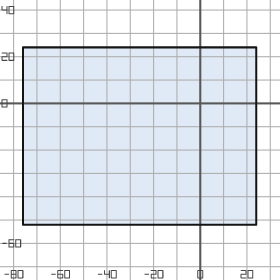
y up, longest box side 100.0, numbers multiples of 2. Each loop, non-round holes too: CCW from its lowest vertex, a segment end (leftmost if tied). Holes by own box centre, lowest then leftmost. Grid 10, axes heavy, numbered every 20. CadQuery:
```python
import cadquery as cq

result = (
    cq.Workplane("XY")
    .moveTo(-76.0, -52.0)
    .lineTo(24.0, -52.0)
    .lineTo(24.0, 24.0)
    .lineTo(-76.0, 24.0)
    .close()
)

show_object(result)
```